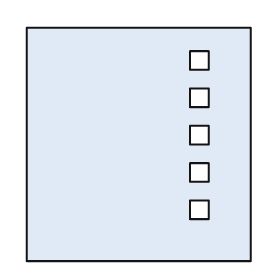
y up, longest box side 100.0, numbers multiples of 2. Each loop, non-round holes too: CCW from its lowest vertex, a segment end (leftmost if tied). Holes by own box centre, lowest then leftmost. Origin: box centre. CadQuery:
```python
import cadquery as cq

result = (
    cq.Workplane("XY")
    .moveTo(-48.0, -50.0)
    .lineTo(48.0, -50.0)
    .lineTo(48.0, 50.0)
    .lineTo(-48.0, 50.0)
    .close()
    .moveTo(22.0, -32.0)
    .lineTo(30.0, -32.0)
    .lineTo(30.0, -24.0)
    .lineTo(22.0, -24.0)
    .close()
    .moveTo(22.0, -16.0)
    .lineTo(30.0, -16.0)
    .lineTo(30.0, -8.0)
    .lineTo(22.0, -8.0)
    .close()
    .moveTo(22.0, 0.0)
    .lineTo(30.0, 0.0)
    .lineTo(30.0, 8.0)
    .lineTo(22.0, 8.0)
    .close()
    .moveTo(22.0, 16.0)
    .lineTo(30.0, 16.0)
    .lineTo(30.0, 24.0)
    .lineTo(22.0, 24.0)
    .close()
    .moveTo(22.0, 32.0)
    .lineTo(30.0, 32.0)
    .lineTo(30.0, 40.0)
    .lineTo(22.0, 40.0)
    .close()
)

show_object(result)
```